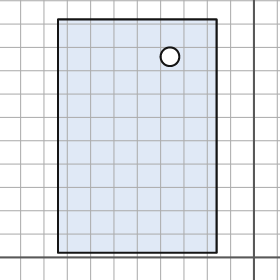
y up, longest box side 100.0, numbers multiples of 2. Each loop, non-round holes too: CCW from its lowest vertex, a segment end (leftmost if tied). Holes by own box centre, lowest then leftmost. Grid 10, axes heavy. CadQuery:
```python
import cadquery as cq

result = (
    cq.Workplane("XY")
    .moveTo(-84.0, 2.0)
    .lineTo(-16.0, 2.0)
    .lineTo(-16.0, 102.0)
    .lineTo(-84.0, 102.0)
    .close()
    .moveTo(-36.0, 86.0)
    .circle(4.0)
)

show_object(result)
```